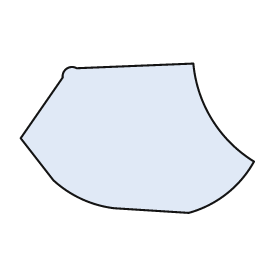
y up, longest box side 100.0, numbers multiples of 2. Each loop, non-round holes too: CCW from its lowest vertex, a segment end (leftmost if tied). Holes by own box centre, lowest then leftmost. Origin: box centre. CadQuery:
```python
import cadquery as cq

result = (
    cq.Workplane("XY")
    .moveTo(22.0, -32.0)
    .threePointArc((38.0, -24.0), (50.0, -10.0))
    .threePointArc((32.0, 8.0), (24.0, 32.0))
    .lineTo(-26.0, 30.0)
    .threePointArc((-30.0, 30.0), (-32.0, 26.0))
    .lineTo(-50.0, 0.0)
    .lineTo(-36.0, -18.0)
    .threePointArc((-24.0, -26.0), (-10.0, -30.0))
    .close()
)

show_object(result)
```